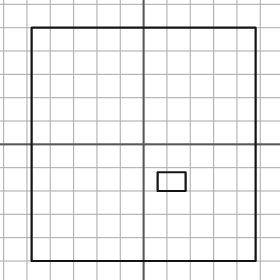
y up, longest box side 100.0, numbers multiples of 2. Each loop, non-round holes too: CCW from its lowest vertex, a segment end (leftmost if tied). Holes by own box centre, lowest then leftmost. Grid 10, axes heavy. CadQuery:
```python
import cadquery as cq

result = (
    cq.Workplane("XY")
    .moveTo(-48.0, -50.0)
    .lineTo(48.0, -50.0)
    .lineTo(48.0, 50.0)
    .lineTo(-48.0, 50.0)
    .close()
    .moveTo(6.0, -20.0)
    .lineTo(18.0, -20.0)
    .lineTo(18.0, -12.0)
    .lineTo(6.0, -12.0)
    .close()
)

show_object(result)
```